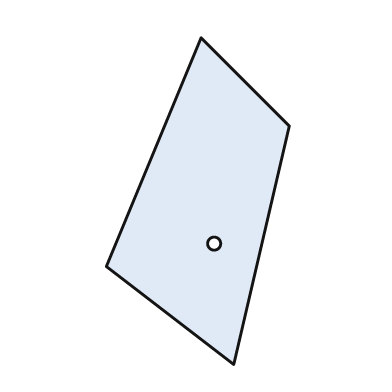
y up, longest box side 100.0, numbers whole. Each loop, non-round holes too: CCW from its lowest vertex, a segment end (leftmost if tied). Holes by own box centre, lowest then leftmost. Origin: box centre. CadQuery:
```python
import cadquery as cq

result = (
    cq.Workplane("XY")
    .moveTo(11.0, -50.0)
    .lineTo(28.0, 23.0)
    .lineTo(1.0, 50.0)
    .lineTo(-28.0, -20.0)
    .close()
    .moveTo(5.0, -13.0)
    .circle(2.0)
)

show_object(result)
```